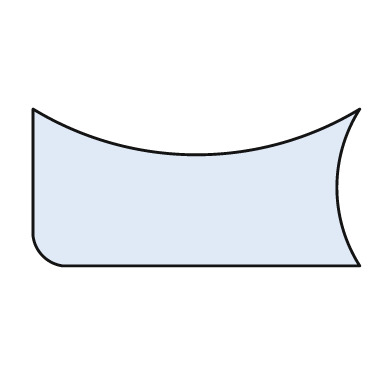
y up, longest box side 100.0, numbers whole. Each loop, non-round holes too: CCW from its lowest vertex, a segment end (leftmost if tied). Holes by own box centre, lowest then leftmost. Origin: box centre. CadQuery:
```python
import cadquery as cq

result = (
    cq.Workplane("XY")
    .moveTo(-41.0, -24.0)
    .lineTo(50.0, -24.0)
    .threePointArc((43.0, 0.0), (50.0, 24.0))
    .threePointArc((0.0, 10.0), (-50.0, 24.0))
    .lineTo(-50.0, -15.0)
    .threePointArc((-47.0, -21.0), (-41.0, -24.0))
    .close()
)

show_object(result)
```